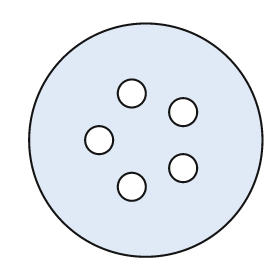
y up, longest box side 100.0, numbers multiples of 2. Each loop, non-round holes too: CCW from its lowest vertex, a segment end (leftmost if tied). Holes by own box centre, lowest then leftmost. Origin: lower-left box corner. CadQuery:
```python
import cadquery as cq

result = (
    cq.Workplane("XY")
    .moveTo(50.0, 50.0)
    .circle(50.0)
    .moveTo(44.0, 30.0)
    .circle(6.0)
    .moveTo(66.0, 38.0)
    .circle(6.0)
    .moveTo(30.0, 50.0)
    .circle(6.0)
    .moveTo(66.0, 62.0)
    .circle(6.0)
    .moveTo(44.0, 70.0)
    .circle(6.0)
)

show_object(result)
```